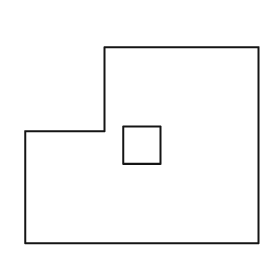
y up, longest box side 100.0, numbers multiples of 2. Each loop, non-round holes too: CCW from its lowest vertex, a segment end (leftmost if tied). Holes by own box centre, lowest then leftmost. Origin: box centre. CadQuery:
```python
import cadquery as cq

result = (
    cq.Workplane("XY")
    .moveTo(-50.0, -42.0)
    .lineTo(50.0, -42.0)
    .lineTo(50.0, 42.0)
    .lineTo(-16.0, 42.0)
    .lineTo(-16.0, 6.0)
    .lineTo(-50.0, 6.0)
    .close()
    .moveTo(-8.0, -8.0)
    .lineTo(8.0, -8.0)
    .lineTo(8.0, 8.0)
    .lineTo(-8.0, 8.0)
    .close()
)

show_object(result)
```